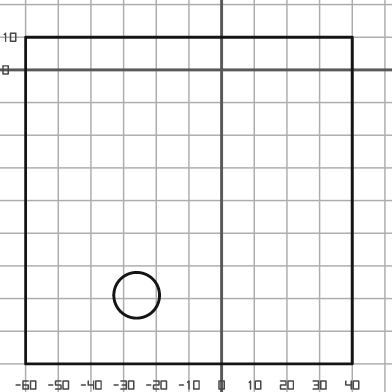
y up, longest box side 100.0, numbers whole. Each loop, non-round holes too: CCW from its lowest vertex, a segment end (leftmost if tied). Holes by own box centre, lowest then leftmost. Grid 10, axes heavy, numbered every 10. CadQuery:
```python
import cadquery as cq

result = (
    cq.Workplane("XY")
    .moveTo(-60.0, -90.0)
    .lineTo(40.0, -90.0)
    .lineTo(40.0, 10.0)
    .lineTo(-60.0, 10.0)
    .close()
    .moveTo(-26.0, -69.0)
    .circle(7.0)
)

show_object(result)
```